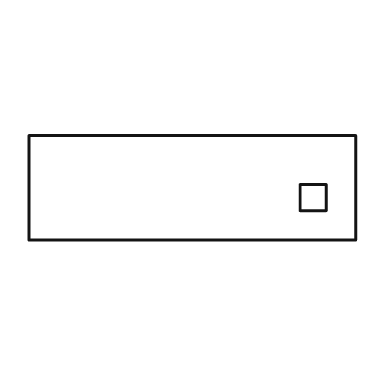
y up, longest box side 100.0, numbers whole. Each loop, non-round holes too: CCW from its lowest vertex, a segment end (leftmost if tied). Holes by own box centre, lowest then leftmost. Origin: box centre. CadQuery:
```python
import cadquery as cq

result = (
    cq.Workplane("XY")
    .moveTo(-50.0, -16.0)
    .lineTo(50.0, -16.0)
    .lineTo(50.0, 16.0)
    .lineTo(-50.0, 16.0)
    .close()
    .moveTo(33.0, -7.0)
    .lineTo(41.0, -7.0)
    .lineTo(41.0, 1.0)
    .lineTo(33.0, 1.0)
    .close()
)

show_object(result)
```